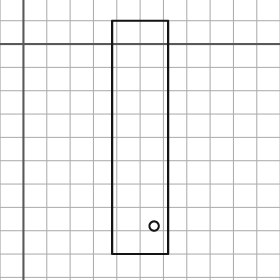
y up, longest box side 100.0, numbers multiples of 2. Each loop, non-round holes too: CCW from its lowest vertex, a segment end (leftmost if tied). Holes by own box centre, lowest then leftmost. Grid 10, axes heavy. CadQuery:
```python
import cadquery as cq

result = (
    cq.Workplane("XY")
    .moveTo(38.0, -90.0)
    .lineTo(62.0, -90.0)
    .lineTo(62.0, 10.0)
    .lineTo(38.0, 10.0)
    .close()
    .moveTo(56.0, -78.0)
    .circle(2.0)
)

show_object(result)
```